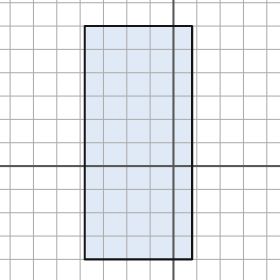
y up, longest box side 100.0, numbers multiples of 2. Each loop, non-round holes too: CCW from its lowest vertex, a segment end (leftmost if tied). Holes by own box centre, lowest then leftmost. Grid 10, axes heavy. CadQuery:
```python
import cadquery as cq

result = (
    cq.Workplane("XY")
    .moveTo(-38.0, -40.0)
    .lineTo(8.0, -40.0)
    .lineTo(8.0, 60.0)
    .lineTo(-38.0, 60.0)
    .close()
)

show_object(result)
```